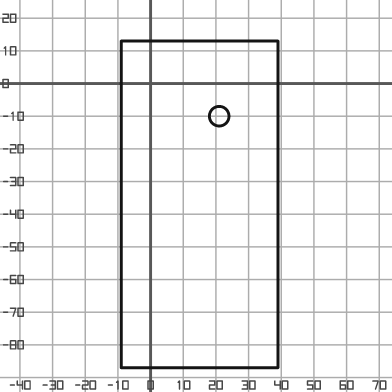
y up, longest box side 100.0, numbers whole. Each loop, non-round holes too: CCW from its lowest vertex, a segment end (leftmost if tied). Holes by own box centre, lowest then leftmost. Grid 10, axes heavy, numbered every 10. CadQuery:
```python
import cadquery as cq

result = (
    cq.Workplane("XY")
    .moveTo(-9.0, -87.0)
    .lineTo(39.0, -87.0)
    .lineTo(39.0, 13.0)
    .lineTo(-9.0, 13.0)
    .close()
    .moveTo(21.0, -10.0)
    .circle(3.0)
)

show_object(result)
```